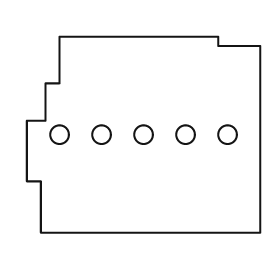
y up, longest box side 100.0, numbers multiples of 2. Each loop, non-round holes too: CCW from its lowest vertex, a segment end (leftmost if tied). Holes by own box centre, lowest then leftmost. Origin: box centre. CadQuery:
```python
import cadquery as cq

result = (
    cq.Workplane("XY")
    .moveTo(-44.0, -42.0)
    .lineTo(50.0, -42.0)
    .lineTo(50.0, 38.0)
    .lineTo(32.0, 38.0)
    .lineTo(32.0, 42.0)
    .lineTo(-36.0, 42.0)
    .lineTo(-36.0, 22.0)
    .lineTo(-42.0, 22.0)
    .lineTo(-42.0, 6.0)
    .lineTo(-50.0, 6.0)
    .lineTo(-50.0, -20.0)
    .lineTo(-44.0, -20.0)
    .close()
    .moveTo(-36.0, 0.0)
    .circle(4.0)
    .moveTo(-18.0, 0.0)
    .circle(4.0)
    .moveTo(0.0, 0.0)
    .circle(4.0)
    .moveTo(18.0, 0.0)
    .circle(4.0)
    .moveTo(36.0, 0.0)
    .circle(4.0)
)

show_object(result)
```